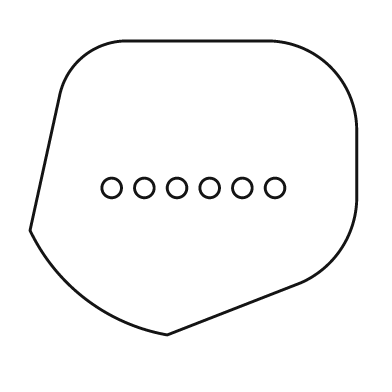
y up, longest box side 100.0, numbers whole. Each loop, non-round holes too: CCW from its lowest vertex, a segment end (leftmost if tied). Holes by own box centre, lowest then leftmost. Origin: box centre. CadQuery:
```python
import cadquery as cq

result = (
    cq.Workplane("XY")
    .moveTo(-8.0, -45.0)
    .lineTo(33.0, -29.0)
    .threePointArc((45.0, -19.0), (50.0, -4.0))
    .lineTo(50.0, 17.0)
    .threePointArc((42.0, 37.0), (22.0, 45.0))
    .lineTo(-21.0, 45.0)
    .threePointArc((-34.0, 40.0), (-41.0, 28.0))
    .lineTo(-50.0, -13.0)
    .threePointArc((-33.0, -34.0), (-8.0, -45.0))
    .close()
    .moveTo(-25.0, 0.0)
    .circle(3.0)
    .moveTo(-15.0, 0.0)
    .circle(3.0)
    .moveTo(-5.0, 0.0)
    .circle(3.0)
    .moveTo(5.0, 0.0)
    .circle(3.0)
    .moveTo(15.0, 0.0)
    .circle(3.0)
    .moveTo(25.0, 0.0)
    .circle(3.0)
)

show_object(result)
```